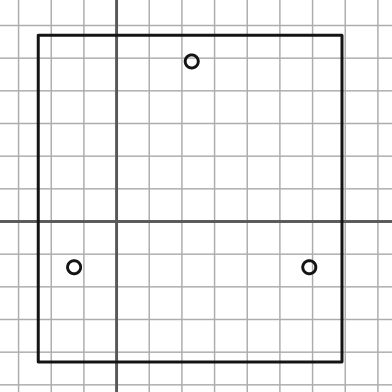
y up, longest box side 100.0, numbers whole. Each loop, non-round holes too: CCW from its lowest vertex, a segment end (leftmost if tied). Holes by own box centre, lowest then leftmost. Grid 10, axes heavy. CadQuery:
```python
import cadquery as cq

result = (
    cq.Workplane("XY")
    .moveTo(-24.0, -43.0)
    .lineTo(69.0, -43.0)
    .lineTo(69.0, 57.0)
    .lineTo(-24.0, 57.0)
    .close()
    .moveTo(-13.0, -14.0)
    .circle(2.0)
    .moveTo(59.0, -14.0)
    .circle(2.0)
    .moveTo(23.0, 49.0)
    .circle(2.0)
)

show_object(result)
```